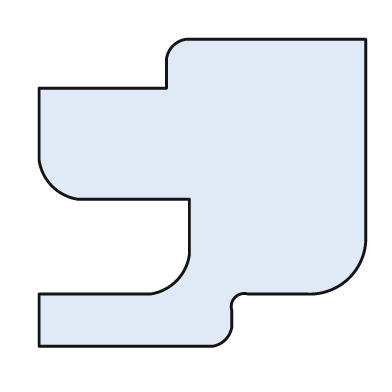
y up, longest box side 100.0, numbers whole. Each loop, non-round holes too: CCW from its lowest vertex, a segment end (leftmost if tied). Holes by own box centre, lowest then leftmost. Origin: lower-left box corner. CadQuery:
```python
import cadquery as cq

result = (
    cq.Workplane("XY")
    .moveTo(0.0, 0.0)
    .lineTo(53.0, 0.0)
    .threePointArc((57.0, 2.0), (59.0, 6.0))
    .lineTo(59.0, 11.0)
    .threePointArc((60.0, 15.0), (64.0, 16.0))
    .lineTo(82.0, 16.0)
    .threePointArc((95.0, 21.0), (100.0, 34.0))
    .lineTo(100.0, 94.0)
    .lineTo(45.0, 94.0)
    .threePointArc((41.0, 92.0), (39.0, 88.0))
    .lineTo(39.0, 79.0)
    .lineTo(0.0, 79.0)
    .lineTo(0.0, 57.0)
    .threePointArc((4.0, 49.0), (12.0, 45.0))
    .lineTo(46.0, 45.0)
    .lineTo(46.0, 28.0)
    .threePointArc((42.0, 20.0), (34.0, 16.0))
    .lineTo(0.0, 16.0)
    .close()
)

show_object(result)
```